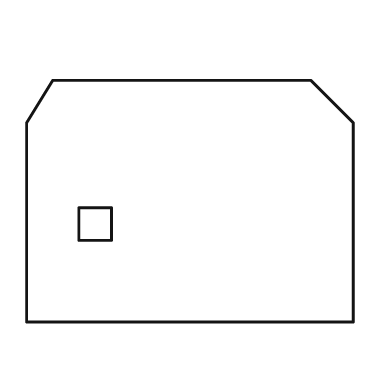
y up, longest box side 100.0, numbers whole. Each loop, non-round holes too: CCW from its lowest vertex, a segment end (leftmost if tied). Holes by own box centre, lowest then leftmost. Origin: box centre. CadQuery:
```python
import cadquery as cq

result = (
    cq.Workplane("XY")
    .moveTo(-50.0, -37.0)
    .lineTo(50.0, -37.0)
    .lineTo(50.0, 24.0)
    .lineTo(37.0, 37.0)
    .lineTo(-42.0, 37.0)
    .lineTo(-50.0, 24.0)
    .close()
    .moveTo(-34.0, -12.0)
    .lineTo(-24.0, -12.0)
    .lineTo(-24.0, -2.0)
    .lineTo(-34.0, -2.0)
    .close()
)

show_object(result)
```